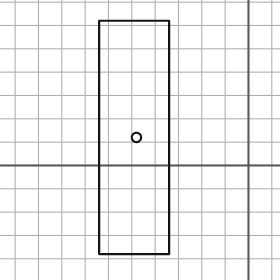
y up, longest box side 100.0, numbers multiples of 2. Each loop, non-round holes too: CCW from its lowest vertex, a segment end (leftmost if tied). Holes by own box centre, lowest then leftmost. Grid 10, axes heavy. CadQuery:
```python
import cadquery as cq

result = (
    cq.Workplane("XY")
    .moveTo(-64.0, -38.0)
    .lineTo(-34.0, -38.0)
    .lineTo(-34.0, 62.0)
    .lineTo(-64.0, 62.0)
    .close()
    .moveTo(-48.0, 12.0)
    .circle(2.0)
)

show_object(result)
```